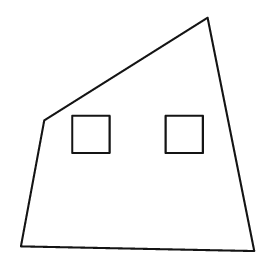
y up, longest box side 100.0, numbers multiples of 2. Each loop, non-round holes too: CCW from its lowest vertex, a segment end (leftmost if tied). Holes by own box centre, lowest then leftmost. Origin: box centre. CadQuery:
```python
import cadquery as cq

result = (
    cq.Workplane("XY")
    .moveTo(50.0, -50.0)
    .lineTo(30.0, 50.0)
    .lineTo(-40.0, 6.0)
    .lineTo(-50.0, -48.0)
    .close()
    .moveTo(-28.0, -8.0)
    .lineTo(-12.0, -8.0)
    .lineTo(-12.0, 8.0)
    .lineTo(-28.0, 8.0)
    .close()
    .moveTo(12.0, -8.0)
    .lineTo(28.0, -8.0)
    .lineTo(28.0, 8.0)
    .lineTo(12.0, 8.0)
    .close()
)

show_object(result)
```